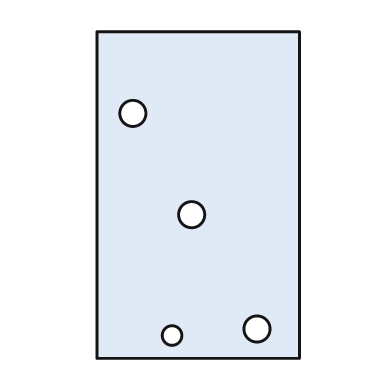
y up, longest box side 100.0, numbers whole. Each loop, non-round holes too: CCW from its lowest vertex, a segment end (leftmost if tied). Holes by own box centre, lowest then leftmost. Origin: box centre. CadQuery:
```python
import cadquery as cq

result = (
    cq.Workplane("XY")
    .moveTo(-31.0, -50.0)
    .lineTo(31.0, -50.0)
    .lineTo(31.0, 50.0)
    .lineTo(-31.0, 50.0)
    .close()
    .moveTo(-8.0, -43.0)
    .circle(3.0)
    .moveTo(18.0, -41.0)
    .circle(4.0)
    .moveTo(-2.0, -6.0)
    .circle(4.0)
    .moveTo(-20.0, 25.0)
    .circle(4.0)
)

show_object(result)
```